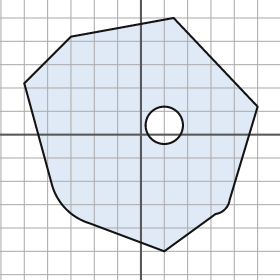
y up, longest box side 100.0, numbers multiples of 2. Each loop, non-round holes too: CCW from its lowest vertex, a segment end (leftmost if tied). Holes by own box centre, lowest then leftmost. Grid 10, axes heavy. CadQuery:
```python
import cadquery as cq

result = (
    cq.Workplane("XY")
    .moveTo(10.0, -50.0)
    .lineTo(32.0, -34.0)
    .threePointArc((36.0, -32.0), (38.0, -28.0))
    .lineTo(50.0, 12.0)
    .lineTo(14.0, 50.0)
    .lineTo(-30.0, 42.0)
    .lineTo(-50.0, 22.0)
    .lineTo(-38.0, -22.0)
    .threePointArc((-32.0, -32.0), (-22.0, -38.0))
    .close()
    .moveTo(10.0, 4.0)
    .circle(8.0)
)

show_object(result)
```